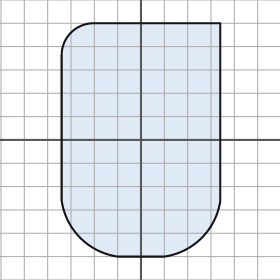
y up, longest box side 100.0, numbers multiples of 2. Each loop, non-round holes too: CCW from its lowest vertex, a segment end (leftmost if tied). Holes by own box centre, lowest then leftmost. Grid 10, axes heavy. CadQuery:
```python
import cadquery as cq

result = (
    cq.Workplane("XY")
    .moveTo(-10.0, -50.0)
    .lineTo(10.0, -50.0)
    .threePointArc((26.0, -42.0), (34.0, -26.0))
    .lineTo(34.0, 50.0)
    .lineTo(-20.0, 50.0)
    .threePointArc((-30.0, 46.0), (-34.0, 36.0))
    .lineTo(-34.0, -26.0)
    .threePointArc((-26.0, -42.0), (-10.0, -50.0))
    .close()
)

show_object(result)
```